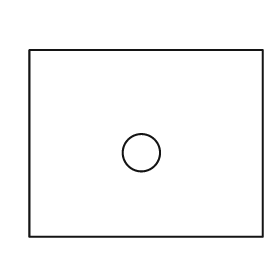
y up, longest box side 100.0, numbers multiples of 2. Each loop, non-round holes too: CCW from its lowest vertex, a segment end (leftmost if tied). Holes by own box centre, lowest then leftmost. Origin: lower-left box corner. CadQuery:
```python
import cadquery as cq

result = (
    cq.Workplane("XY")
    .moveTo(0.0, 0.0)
    .lineTo(100.0, 0.0)
    .lineTo(100.0, 80.0)
    .lineTo(0.0, 80.0)
    .close()
    .moveTo(48.0, 36.0)
    .circle(8.0)
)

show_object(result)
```